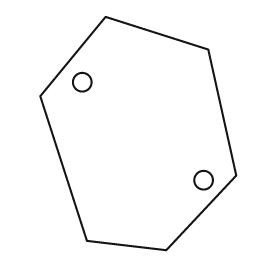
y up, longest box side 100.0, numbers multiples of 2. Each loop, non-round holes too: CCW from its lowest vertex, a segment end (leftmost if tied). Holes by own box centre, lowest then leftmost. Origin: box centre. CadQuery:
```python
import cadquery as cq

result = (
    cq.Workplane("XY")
    .moveTo(12.0, -50.0)
    .lineTo(42.0, -18.0)
    .lineTo(30.0, 36.0)
    .lineTo(-14.0, 50.0)
    .lineTo(-42.0, 16.0)
    .lineTo(-22.0, -46.0)
    .close()
    .moveTo(28.0, -20.0)
    .circle(4.0)
    .moveTo(-24.0, 22.0)
    .circle(4.0)
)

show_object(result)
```